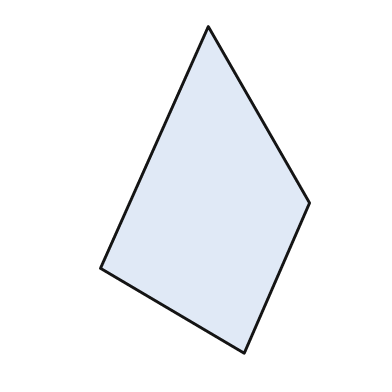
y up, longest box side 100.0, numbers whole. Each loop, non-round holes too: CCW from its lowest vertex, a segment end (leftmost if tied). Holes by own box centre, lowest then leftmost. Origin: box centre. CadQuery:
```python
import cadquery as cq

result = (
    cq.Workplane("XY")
    .moveTo(12.0, -50.0)
    .lineTo(32.0, -4.0)
    .lineTo(1.0, 50.0)
    .lineTo(-32.0, -24.0)
    .close()
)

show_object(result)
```